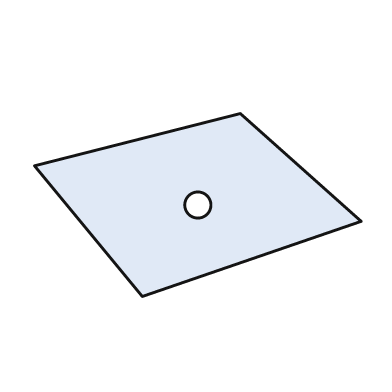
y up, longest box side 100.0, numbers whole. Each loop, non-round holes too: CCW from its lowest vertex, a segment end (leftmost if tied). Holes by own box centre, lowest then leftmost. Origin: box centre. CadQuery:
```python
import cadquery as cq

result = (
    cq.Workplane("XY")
    .moveTo(-17.0, -28.0)
    .lineTo(50.0, -5.0)
    .lineTo(13.0, 28.0)
    .lineTo(-50.0, 12.0)
    .close()
    .moveTo(0.0, 0.0)
    .circle(4.0)
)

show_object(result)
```